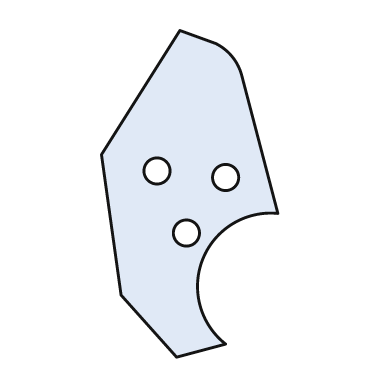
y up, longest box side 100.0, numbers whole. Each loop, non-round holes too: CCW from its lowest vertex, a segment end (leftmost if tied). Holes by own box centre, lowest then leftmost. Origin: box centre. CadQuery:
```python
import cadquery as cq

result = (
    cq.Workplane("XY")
    .moveTo(-4.0, -50.0)
    .lineTo(11.0, -46.0)
    .threePointArc((4.0, -20.0), (27.0, -6.0))
    .lineTo(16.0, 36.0)
    .threePointArc((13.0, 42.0), (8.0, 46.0))
    .lineTo(-3.0, 50.0)
    .lineTo(-27.0, 12.0)
    .lineTo(-21.0, -31.0)
    .close()
    .moveTo(-1.0, -12.0)
    .circle(4.0)
    .moveTo(11.0, 5.0)
    .circle(4.0)
    .moveTo(-10.0, 7.0)
    .circle(4.0)
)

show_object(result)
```